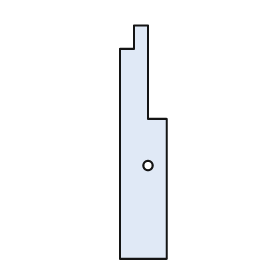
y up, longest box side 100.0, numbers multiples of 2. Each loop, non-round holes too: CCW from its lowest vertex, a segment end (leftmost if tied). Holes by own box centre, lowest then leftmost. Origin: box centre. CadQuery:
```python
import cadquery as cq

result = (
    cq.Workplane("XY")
    .moveTo(-10.0, -50.0)
    .lineTo(10.0, -50.0)
    .lineTo(10.0, 10.0)
    .lineTo(2.0, 10.0)
    .lineTo(2.0, 50.0)
    .lineTo(-4.0, 50.0)
    .lineTo(-4.0, 40.0)
    .lineTo(-10.0, 40.0)
    .close()
    .moveTo(2.0, -10.0)
    .circle(2.0)
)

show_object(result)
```